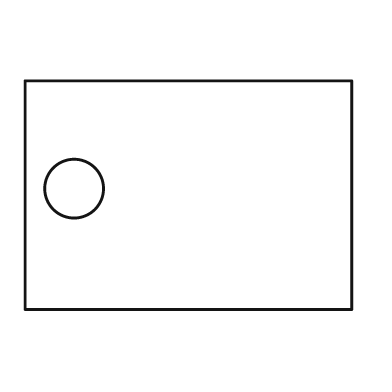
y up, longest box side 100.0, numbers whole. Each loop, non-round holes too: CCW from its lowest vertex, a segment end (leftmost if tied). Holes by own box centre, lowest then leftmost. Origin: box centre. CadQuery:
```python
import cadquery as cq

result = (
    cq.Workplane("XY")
    .moveTo(-50.0, -35.0)
    .lineTo(50.0, -35.0)
    .lineTo(50.0, 35.0)
    .lineTo(-50.0, 35.0)
    .close()
    .moveTo(-35.0, 2.0)
    .circle(9.0)
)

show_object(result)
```